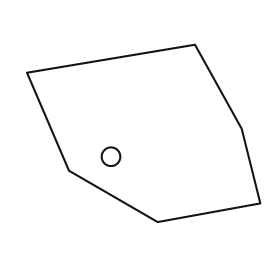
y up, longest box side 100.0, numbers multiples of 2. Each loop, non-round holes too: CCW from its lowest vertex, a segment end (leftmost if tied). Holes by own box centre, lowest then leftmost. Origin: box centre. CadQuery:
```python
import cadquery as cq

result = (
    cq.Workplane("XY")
    .moveTo(6.0, -38.0)
    .lineTo(50.0, -30.0)
    .lineTo(42.0, 2.0)
    .lineTo(22.0, 38.0)
    .lineTo(-50.0, 26.0)
    .lineTo(-32.0, -16.0)
    .close()
    .moveTo(-14.0, -10.0)
    .circle(4.0)
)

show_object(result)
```